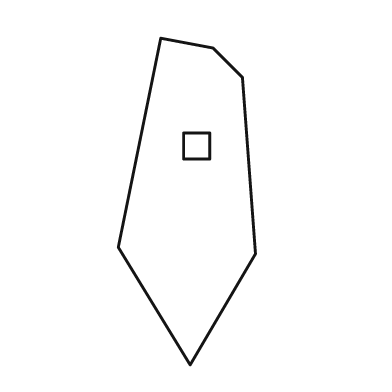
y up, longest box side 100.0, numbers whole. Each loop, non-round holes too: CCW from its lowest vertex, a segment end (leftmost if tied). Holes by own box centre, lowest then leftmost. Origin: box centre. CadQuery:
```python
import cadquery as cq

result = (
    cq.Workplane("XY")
    .moveTo(1.0, -50.0)
    .lineTo(21.0, -16.0)
    .lineTo(17.0, 38.0)
    .lineTo(8.0, 47.0)
    .lineTo(-8.0, 50.0)
    .lineTo(-21.0, -14.0)
    .close()
    .moveTo(-1.0, 13.0)
    .lineTo(7.0, 13.0)
    .lineTo(7.0, 21.0)
    .lineTo(-1.0, 21.0)
    .close()
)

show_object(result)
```